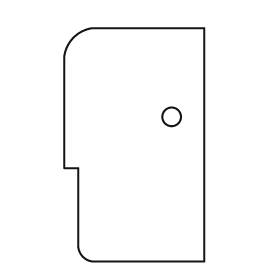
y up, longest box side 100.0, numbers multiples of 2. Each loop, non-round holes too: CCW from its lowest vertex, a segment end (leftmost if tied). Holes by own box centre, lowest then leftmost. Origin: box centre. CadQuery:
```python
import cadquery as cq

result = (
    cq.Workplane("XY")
    .moveTo(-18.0, -50.0)
    .lineTo(30.0, -50.0)
    .lineTo(30.0, 50.0)
    .lineTo(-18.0, 50.0)
    .threePointArc((-26.0, 46.0), (-30.0, 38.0))
    .lineTo(-30.0, -10.0)
    .lineTo(-24.0, -10.0)
    .lineTo(-24.0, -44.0)
    .threePointArc((-22.0, -48.0), (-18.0, -50.0))
    .close()
    .moveTo(16.0, 12.0)
    .circle(4.0)
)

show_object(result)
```